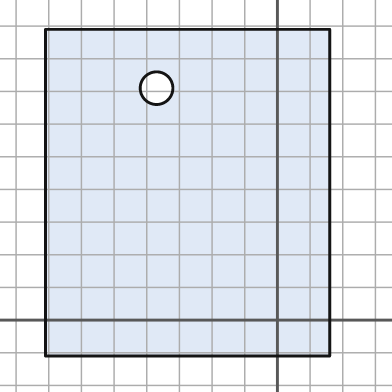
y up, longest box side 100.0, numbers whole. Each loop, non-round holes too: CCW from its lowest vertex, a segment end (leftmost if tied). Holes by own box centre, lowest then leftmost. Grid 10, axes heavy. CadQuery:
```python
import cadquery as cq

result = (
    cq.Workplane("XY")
    .moveTo(-71.0, -11.0)
    .lineTo(16.0, -11.0)
    .lineTo(16.0, 89.0)
    .lineTo(-71.0, 89.0)
    .close()
    .moveTo(-37.0, 71.0)
    .circle(5.0)
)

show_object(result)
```